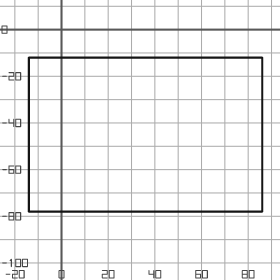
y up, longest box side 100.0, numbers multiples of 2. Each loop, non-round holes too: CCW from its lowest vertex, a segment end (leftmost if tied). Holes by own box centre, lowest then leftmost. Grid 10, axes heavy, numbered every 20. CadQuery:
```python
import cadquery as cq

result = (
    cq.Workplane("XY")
    .moveTo(-14.0, -78.0)
    .lineTo(86.0, -78.0)
    .lineTo(86.0, -12.0)
    .lineTo(-14.0, -12.0)
    .close()
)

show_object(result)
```